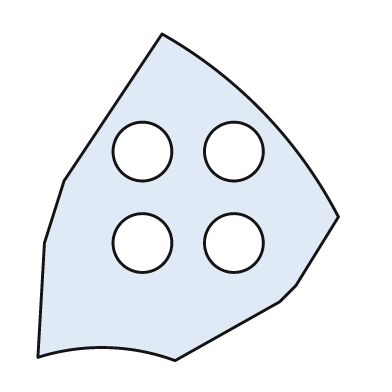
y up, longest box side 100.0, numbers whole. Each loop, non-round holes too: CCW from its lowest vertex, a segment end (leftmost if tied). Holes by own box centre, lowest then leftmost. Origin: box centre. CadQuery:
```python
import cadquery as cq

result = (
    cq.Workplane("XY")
    .moveTo(-4.0, -50.0)
    .lineTo(28.0, -32.0)
    .lineTo(33.0, -27.0)
    .lineTo(46.0, -6.0)
    .threePointArc((23.0, 26.0), (-8.0, 50.0))
    .lineTo(-38.0, 5.0)
    .lineTo(-44.0, -14.0)
    .lineTo(-46.0, -49.0)
    .threePointArc((-25.0, -46.0), (-4.0, -50.0))
    .close()
    .moveTo(-14.0, -14.0)
    .circle(9.0)
    .moveTo(14.0, -14.0)
    .circle(9.0)
    .moveTo(-14.0, 14.0)
    .circle(9.0)
    .moveTo(14.0, 14.0)
    .circle(9.0)
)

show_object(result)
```